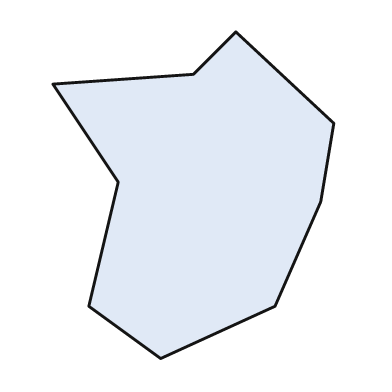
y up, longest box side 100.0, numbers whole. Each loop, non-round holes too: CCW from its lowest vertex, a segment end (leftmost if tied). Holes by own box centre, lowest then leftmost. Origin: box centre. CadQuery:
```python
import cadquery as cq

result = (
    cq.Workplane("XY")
    .moveTo(-10.0, -50.0)
    .lineTo(25.0, -34.0)
    .lineTo(39.0, -2.0)
    .lineTo(43.0, 22.0)
    .lineTo(13.0, 50.0)
    .lineTo(0.0, 37.0)
    .lineTo(-43.0, 34.0)
    .lineTo(-23.0, 4.0)
    .lineTo(-32.0, -34.0)
    .close()
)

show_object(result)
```